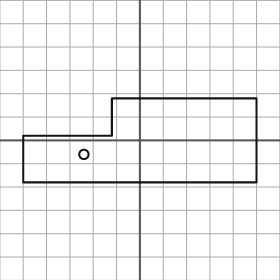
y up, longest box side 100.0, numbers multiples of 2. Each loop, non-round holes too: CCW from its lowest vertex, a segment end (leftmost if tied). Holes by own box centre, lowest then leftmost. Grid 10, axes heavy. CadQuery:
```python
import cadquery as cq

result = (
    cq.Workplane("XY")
    .moveTo(-50.0, -18.0)
    .lineTo(50.0, -18.0)
    .lineTo(50.0, 18.0)
    .lineTo(-12.0, 18.0)
    .lineTo(-12.0, 2.0)
    .lineTo(-50.0, 2.0)
    .close()
    .moveTo(-24.0, -6.0)
    .circle(2.0)
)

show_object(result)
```